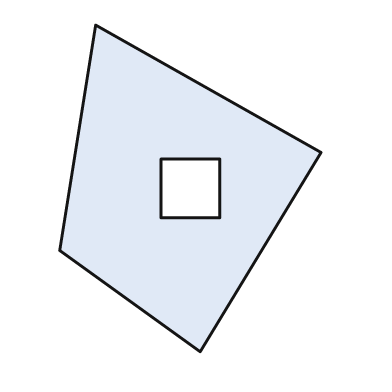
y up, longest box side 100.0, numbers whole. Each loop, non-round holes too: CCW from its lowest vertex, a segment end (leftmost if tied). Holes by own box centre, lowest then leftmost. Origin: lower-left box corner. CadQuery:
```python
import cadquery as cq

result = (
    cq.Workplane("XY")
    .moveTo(43.0, 0.0)
    .lineTo(80.0, 61.0)
    .lineTo(11.0, 100.0)
    .lineTo(0.0, 31.0)
    .close()
    .moveTo(31.0, 41.0)
    .lineTo(49.0, 41.0)
    .lineTo(49.0, 59.0)
    .lineTo(31.0, 59.0)
    .close()
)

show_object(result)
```